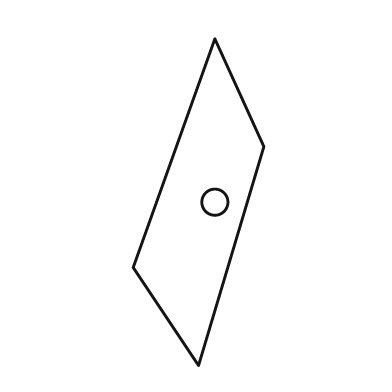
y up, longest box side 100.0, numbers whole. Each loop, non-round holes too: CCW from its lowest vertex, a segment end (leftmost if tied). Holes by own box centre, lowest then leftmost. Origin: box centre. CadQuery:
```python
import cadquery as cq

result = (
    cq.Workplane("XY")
    .moveTo(0.0, -50.0)
    .lineTo(20.0, 17.0)
    .lineTo(5.0, 50.0)
    .lineTo(-20.0, -20.0)
    .close()
    .moveTo(5.0, 0.0)
    .circle(4.0)
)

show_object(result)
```